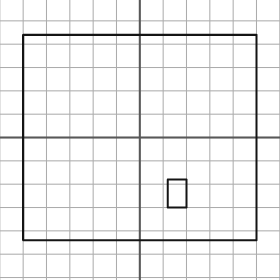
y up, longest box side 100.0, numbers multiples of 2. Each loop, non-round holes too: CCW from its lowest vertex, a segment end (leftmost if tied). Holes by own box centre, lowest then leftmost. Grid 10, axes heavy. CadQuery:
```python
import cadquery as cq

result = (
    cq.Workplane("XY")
    .moveTo(-50.0, -44.0)
    .lineTo(50.0, -44.0)
    .lineTo(50.0, 44.0)
    .lineTo(-50.0, 44.0)
    .close()
    .moveTo(12.0, -30.0)
    .lineTo(20.0, -30.0)
    .lineTo(20.0, -18.0)
    .lineTo(12.0, -18.0)
    .close()
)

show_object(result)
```